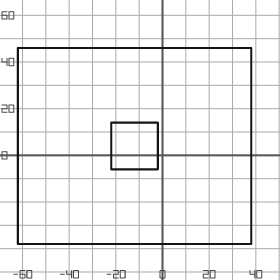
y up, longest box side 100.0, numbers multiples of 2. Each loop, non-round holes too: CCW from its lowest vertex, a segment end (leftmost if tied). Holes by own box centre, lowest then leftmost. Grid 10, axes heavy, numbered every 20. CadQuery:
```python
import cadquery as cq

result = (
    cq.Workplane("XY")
    .moveTo(-62.0, -38.0)
    .lineTo(38.0, -38.0)
    .lineTo(38.0, 46.0)
    .lineTo(-62.0, 46.0)
    .close()
    .moveTo(-22.0, -6.0)
    .lineTo(-2.0, -6.0)
    .lineTo(-2.0, 14.0)
    .lineTo(-22.0, 14.0)
    .close()
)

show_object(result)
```